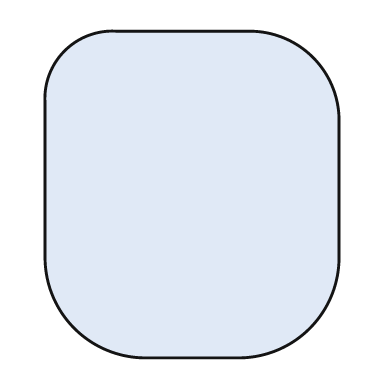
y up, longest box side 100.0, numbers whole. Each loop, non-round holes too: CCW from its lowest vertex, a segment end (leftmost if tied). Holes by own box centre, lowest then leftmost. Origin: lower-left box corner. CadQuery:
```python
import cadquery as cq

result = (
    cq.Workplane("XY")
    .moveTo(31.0, 0.0)
    .lineTo(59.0, 0.0)
    .threePointArc((81.0, 9.0), (90.0, 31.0))
    .lineTo(90.0, 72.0)
    .threePointArc((82.0, 92.0), (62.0, 100.0))
    .lineTo(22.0, 100.0)
    .threePointArc((6.0, 94.0), (0.0, 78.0))
    .lineTo(0.0, 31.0)
    .threePointArc((9.0, 9.0), (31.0, 0.0))
    .close()
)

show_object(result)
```